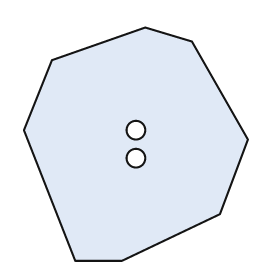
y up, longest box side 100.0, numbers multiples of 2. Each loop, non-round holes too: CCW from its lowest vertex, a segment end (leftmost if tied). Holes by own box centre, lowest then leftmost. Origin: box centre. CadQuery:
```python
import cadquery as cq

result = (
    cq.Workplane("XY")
    .moveTo(-26.0, -50.0)
    .lineTo(-6.0, -50.0)
    .lineTo(36.0, -30.0)
    .lineTo(48.0, 2.0)
    .lineTo(24.0, 44.0)
    .lineTo(4.0, 50.0)
    .lineTo(-36.0, 36.0)
    .lineTo(-48.0, 6.0)
    .close()
    .moveTo(0.0, -6.0)
    .circle(4.0)
    .moveTo(0.0, 6.0)
    .circle(4.0)
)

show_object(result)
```